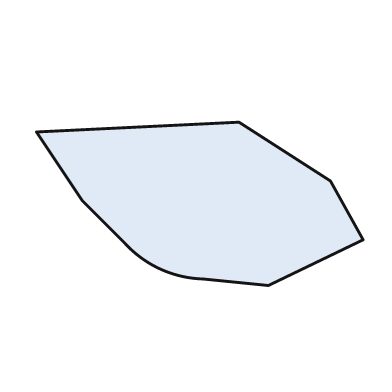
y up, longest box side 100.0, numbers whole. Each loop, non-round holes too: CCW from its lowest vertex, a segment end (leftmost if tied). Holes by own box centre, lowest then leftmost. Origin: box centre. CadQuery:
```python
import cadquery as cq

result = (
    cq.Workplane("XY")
    .moveTo(21.0, -25.0)
    .lineTo(50.0, -11.0)
    .lineTo(40.0, 7.0)
    .lineTo(12.0, 25.0)
    .lineTo(-50.0, 22.0)
    .lineTo(-36.0, 1.0)
    .lineTo(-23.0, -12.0)
    .threePointArc((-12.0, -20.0), (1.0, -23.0))
    .close()
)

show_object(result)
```